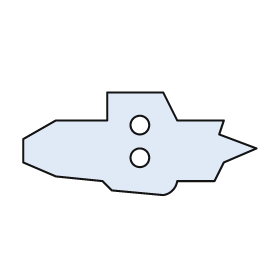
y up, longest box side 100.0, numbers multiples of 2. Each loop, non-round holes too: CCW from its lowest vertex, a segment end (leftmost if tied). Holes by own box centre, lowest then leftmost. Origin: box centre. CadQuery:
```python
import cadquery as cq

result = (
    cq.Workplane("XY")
    .moveTo(10.0, -22.0)
    .threePointArc((14.0, -20.0), (16.0, -16.0))
    .lineTo(32.0, -16.0)
    .lineTo(36.0, -8.0)
    .lineTo(50.0, -2.0)
    .lineTo(34.0, 4.0)
    .lineTo(36.0, 10.0)
    .lineTo(16.0, 10.0)
    .lineTo(10.0, 22.0)
    .lineTo(-14.0, 22.0)
    .lineTo(-14.0, 10.0)
    .lineTo(-36.0, 10.0)
    .lineTo(-50.0, 2.0)
    .lineTo(-50.0, -8.0)
    .lineTo(-36.0, -14.0)
    .lineTo(-16.0, -16.0)
    .lineTo(-12.0, -20.0)
    .close()
    .moveTo(0.0, -6.0)
    .circle(4.0)
    .moveTo(0.0, 8.0)
    .circle(4.0)
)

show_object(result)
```